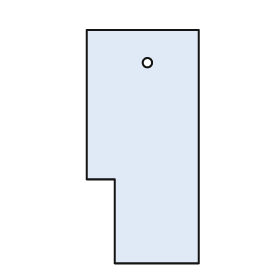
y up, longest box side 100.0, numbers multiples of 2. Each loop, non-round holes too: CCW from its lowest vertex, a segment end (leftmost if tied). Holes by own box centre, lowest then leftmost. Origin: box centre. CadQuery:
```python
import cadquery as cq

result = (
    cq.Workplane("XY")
    .moveTo(-12.0, -50.0)
    .lineTo(24.0, -50.0)
    .lineTo(24.0, 50.0)
    .lineTo(-24.0, 50.0)
    .lineTo(-24.0, -14.0)
    .lineTo(-12.0, -14.0)
    .close()
    .moveTo(2.0, 36.0)
    .circle(2.0)
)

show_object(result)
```